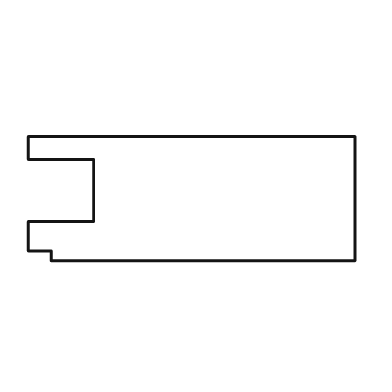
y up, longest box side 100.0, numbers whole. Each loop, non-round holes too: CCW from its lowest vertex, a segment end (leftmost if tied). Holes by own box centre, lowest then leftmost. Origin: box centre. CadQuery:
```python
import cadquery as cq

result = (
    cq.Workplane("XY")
    .moveTo(-43.0, -19.0)
    .lineTo(50.0, -19.0)
    .lineTo(50.0, 19.0)
    .lineTo(-50.0, 19.0)
    .lineTo(-50.0, 12.0)
    .lineTo(-30.0, 12.0)
    .lineTo(-30.0, -7.0)
    .lineTo(-50.0, -7.0)
    .lineTo(-50.0, -16.0)
    .lineTo(-43.0, -16.0)
    .close()
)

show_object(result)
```